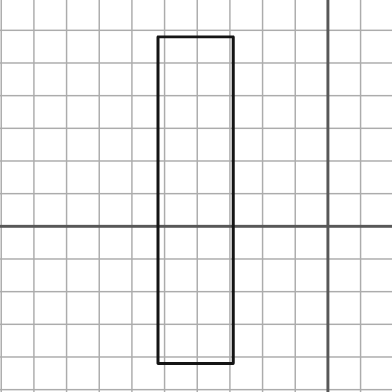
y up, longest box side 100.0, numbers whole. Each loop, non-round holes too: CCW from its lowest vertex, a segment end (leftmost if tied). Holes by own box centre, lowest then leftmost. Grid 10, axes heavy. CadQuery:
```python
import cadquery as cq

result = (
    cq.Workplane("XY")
    .moveTo(-52.0, -42.0)
    .lineTo(-29.0, -42.0)
    .lineTo(-29.0, 58.0)
    .lineTo(-52.0, 58.0)
    .close()
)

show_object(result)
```